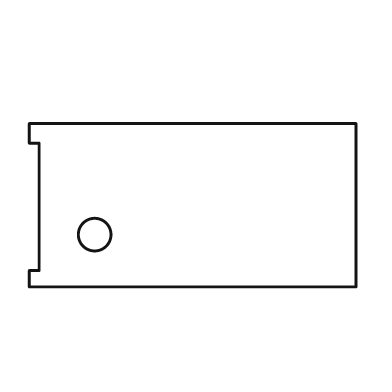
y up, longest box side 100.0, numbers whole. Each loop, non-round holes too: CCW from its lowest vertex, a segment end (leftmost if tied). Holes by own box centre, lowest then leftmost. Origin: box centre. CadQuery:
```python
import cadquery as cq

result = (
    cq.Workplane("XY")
    .moveTo(-50.0, -25.0)
    .lineTo(50.0, -25.0)
    .lineTo(50.0, 25.0)
    .lineTo(-50.0, 25.0)
    .lineTo(-50.0, 19.0)
    .lineTo(-47.0, 19.0)
    .lineTo(-47.0, -20.0)
    .lineTo(-50.0, -20.0)
    .close()
    .moveTo(-30.0, -9.0)
    .circle(5.0)
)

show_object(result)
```